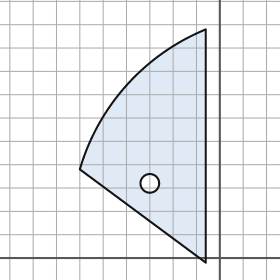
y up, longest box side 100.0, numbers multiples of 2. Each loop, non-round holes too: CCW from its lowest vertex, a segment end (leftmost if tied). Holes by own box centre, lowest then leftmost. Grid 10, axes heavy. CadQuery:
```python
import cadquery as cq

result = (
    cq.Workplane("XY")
    .moveTo(-6.0, -2.0)
    .lineTo(-6.0, 98.0)
    .threePointArc((-40.0, 74.0), (-60.0, 38.0))
    .close()
    .moveTo(-30.0, 32.0)
    .circle(4.0)
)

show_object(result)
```